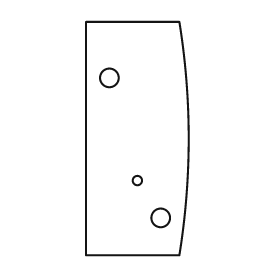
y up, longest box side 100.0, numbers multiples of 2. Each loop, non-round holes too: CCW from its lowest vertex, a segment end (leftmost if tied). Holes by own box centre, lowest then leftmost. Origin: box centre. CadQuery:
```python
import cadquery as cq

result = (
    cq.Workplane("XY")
    .moveTo(-22.0, -50.0)
    .lineTo(18.0, -50.0)
    .threePointArc((22.0, 0.0), (18.0, 50.0))
    .lineTo(-22.0, 50.0)
    .close()
    .moveTo(10.0, -34.0)
    .circle(4.0)
    .moveTo(0.0, -18.0)
    .circle(2.0)
    .moveTo(-12.0, 26.0)
    .circle(4.0)
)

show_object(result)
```